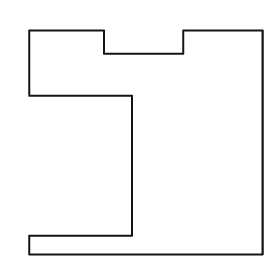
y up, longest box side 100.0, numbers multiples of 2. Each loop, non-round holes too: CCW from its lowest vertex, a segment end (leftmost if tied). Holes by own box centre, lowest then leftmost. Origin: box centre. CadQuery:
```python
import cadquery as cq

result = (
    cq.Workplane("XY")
    .moveTo(-50.0, -48.0)
    .lineTo(50.0, -48.0)
    .lineTo(50.0, 48.0)
    .lineTo(16.0, 48.0)
    .lineTo(16.0, 38.0)
    .lineTo(-18.0, 38.0)
    .lineTo(-18.0, 48.0)
    .lineTo(-50.0, 48.0)
    .lineTo(-50.0, 20.0)
    .lineTo(-6.0, 20.0)
    .lineTo(-6.0, -40.0)
    .lineTo(-50.0, -40.0)
    .close()
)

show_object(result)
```